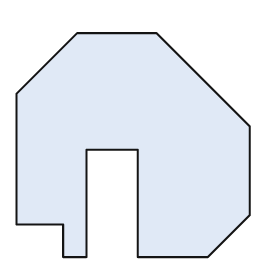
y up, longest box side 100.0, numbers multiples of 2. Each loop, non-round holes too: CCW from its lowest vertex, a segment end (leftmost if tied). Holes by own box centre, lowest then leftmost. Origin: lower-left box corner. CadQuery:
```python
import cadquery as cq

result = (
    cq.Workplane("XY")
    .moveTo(20.0, 0.0)
    .lineTo(30.0, 0.0)
    .lineTo(30.0, 46.0)
    .lineTo(52.0, 46.0)
    .lineTo(52.0, 0.0)
    .lineTo(82.0, 0.0)
    .lineTo(100.0, 18.0)
    .lineTo(100.0, 56.0)
    .lineTo(60.0, 96.0)
    .lineTo(26.0, 96.0)
    .lineTo(0.0, 70.0)
    .lineTo(0.0, 14.0)
    .lineTo(20.0, 14.0)
    .close()
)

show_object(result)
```